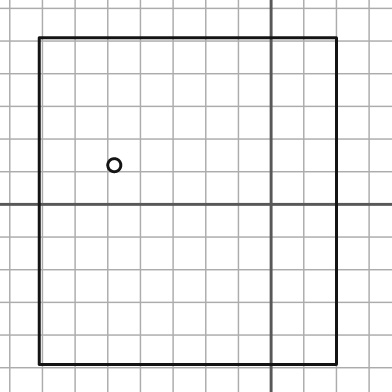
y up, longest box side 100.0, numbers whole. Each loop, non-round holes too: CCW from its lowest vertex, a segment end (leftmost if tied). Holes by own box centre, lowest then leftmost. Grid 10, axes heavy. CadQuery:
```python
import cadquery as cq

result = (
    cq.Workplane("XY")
    .moveTo(-71.0, -49.0)
    .lineTo(20.0, -49.0)
    .lineTo(20.0, 51.0)
    .lineTo(-71.0, 51.0)
    .close()
    .moveTo(-48.0, 12.0)
    .circle(2.0)
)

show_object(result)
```